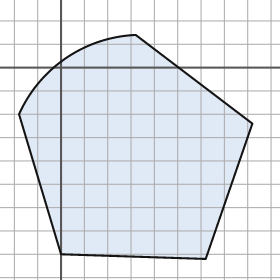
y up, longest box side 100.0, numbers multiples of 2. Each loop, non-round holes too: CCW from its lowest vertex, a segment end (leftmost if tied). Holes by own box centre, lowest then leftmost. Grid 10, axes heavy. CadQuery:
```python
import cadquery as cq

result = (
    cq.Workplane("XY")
    .moveTo(62.0, -82.0)
    .lineTo(82.0, -24.0)
    .lineTo(32.0, 14.0)
    .threePointArc((2.0, 4.0), (-18.0, -20.0))
    .lineTo(0.0, -80.0)
    .close()
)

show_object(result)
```